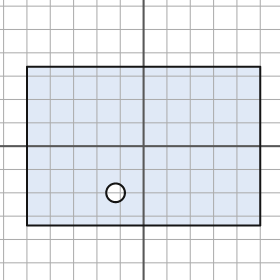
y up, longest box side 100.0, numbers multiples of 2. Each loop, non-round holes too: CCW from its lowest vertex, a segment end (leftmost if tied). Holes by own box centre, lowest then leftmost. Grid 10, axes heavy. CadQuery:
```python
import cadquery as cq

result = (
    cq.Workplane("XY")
    .moveTo(-50.0, -34.0)
    .lineTo(50.0, -34.0)
    .lineTo(50.0, 34.0)
    .lineTo(-50.0, 34.0)
    .close()
    .moveTo(-12.0, -20.0)
    .circle(4.0)
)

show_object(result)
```